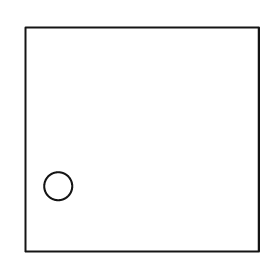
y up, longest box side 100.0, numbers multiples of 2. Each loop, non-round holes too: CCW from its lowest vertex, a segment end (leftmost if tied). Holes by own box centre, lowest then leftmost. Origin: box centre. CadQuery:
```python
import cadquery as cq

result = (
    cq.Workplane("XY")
    .moveTo(-50.0, -48.0)
    .lineTo(50.0, -48.0)
    .lineTo(50.0, 48.0)
    .lineTo(-50.0, 48.0)
    .close()
    .moveTo(-36.0, -20.0)
    .circle(6.0)
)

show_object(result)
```